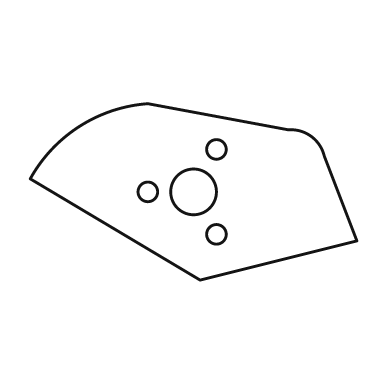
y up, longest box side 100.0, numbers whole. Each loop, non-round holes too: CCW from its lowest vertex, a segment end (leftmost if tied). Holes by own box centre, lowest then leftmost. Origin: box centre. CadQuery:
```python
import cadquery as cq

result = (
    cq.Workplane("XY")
    .moveTo(2.0, -27.0)
    .lineTo(50.0, -15.0)
    .lineTo(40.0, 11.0)
    .threePointArc((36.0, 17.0), (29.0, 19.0))
    .lineTo(-14.0, 27.0)
    .threePointArc((-35.0, 20.0), (-50.0, 4.0))
    .close()
    .moveTo(7.0, -13.0)
    .circle(3.0)
    .moveTo(-14.0, 0.0)
    .circle(3.0)
    .moveTo(0.0, 0.0)
    .circle(7.0)
    .moveTo(7.0, 13.0)
    .circle(3.0)
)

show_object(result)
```